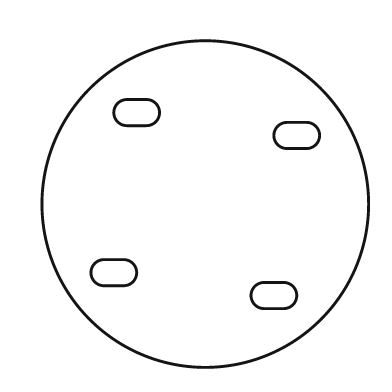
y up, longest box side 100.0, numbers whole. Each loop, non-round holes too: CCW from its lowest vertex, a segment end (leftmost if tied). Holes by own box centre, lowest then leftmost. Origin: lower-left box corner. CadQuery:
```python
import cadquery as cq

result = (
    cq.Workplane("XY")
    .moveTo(50.0, 50.0)
    .circle(50.0)
    .moveTo(68.0, 18.0)
    .lineTo(74.0, 18.0)
    .threePointArc((78.0, 22.0), (74.0, 26.0))
    .lineTo(68.0, 26.0)
    .threePointArc((64.0, 22.0), (68.0, 18.0))
    .close()
    .moveTo(19.0, 25.0)
    .lineTo(25.0, 25.0)
    .threePointArc((29.0, 29.0), (25.0, 33.0))
    .lineTo(19.0, 33.0)
    .threePointArc((15.0, 29.0), (19.0, 25.0))
    .close()
    .moveTo(75.0, 67.0)
    .lineTo(81.0, 67.0)
    .threePointArc((85.0, 71.0), (81.0, 75.0))
    .lineTo(75.0, 75.0)
    .threePointArc((71.0, 71.0), (75.0, 67.0))
    .close()
    .moveTo(26.0, 74.0)
    .lineTo(32.0, 74.0)
    .threePointArc((36.0, 78.0), (32.0, 82.0))
    .lineTo(26.0, 82.0)
    .threePointArc((22.0, 78.0), (26.0, 74.0))
    .close()
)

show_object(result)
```